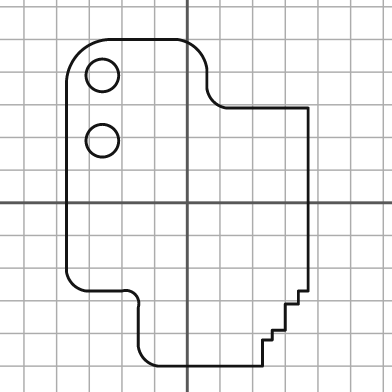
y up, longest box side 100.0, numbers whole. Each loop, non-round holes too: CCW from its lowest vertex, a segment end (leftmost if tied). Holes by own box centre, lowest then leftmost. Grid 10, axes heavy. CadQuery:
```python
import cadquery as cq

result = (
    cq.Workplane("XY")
    .moveTo(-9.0, -50.0)
    .lineTo(23.0, -50.0)
    .lineTo(23.0, -42.0)
    .lineTo(26.0, -42.0)
    .lineTo(26.0, -39.0)
    .lineTo(30.0, -39.0)
    .lineTo(30.0, -31.0)
    .lineTo(34.0, -31.0)
    .lineTo(34.0, -27.0)
    .lineTo(37.0, -27.0)
    .lineTo(37.0, 29.0)
    .lineTo(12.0, 29.0)
    .threePointArc((8.0, 31.0), (6.0, 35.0))
    .lineTo(6.0, 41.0)
    .threePointArc((3.0, 47.0), (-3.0, 50.0))
    .lineTo(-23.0, 50.0)
    .threePointArc((-33.0, 46.0), (-37.0, 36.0))
    .lineTo(-37.0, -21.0)
    .threePointArc((-35.0, -25.0), (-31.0, -27.0))
    .lineTo(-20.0, -27.0)
    .threePointArc((-16.0, -28.0), (-15.0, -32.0))
    .lineTo(-15.0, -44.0)
    .threePointArc((-13.0, -48.0), (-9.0, -50.0))
    .close()
    .moveTo(-26.0, 19.0)
    .circle(5.0)
    .moveTo(-26.0, 39.0)
    .circle(5.0)
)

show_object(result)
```